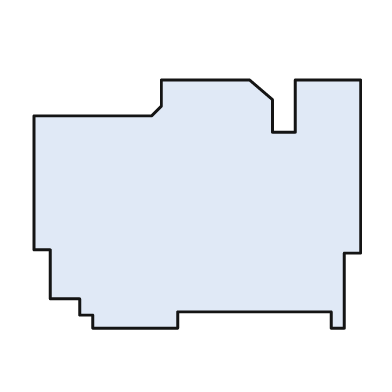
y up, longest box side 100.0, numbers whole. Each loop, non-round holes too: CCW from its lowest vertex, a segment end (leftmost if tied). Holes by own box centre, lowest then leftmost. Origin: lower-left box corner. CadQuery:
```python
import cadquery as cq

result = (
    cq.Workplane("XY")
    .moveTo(18.0, 0.0)
    .lineTo(44.0, 0.0)
    .lineTo(44.0, 5.0)
    .lineTo(91.0, 5.0)
    .lineTo(91.0, 0.0)
    .lineTo(95.0, 0.0)
    .lineTo(95.0, 23.0)
    .lineTo(100.0, 23.0)
    .lineTo(100.0, 76.0)
    .lineTo(80.0, 76.0)
    .lineTo(80.0, 60.0)
    .lineTo(73.0, 60.0)
    .lineTo(73.0, 70.0)
    .lineTo(66.0, 76.0)
    .lineTo(39.0, 76.0)
    .lineTo(39.0, 68.0)
    .lineTo(36.0, 65.0)
    .lineTo(0.0, 65.0)
    .lineTo(0.0, 24.0)
    .lineTo(5.0, 24.0)
    .lineTo(5.0, 9.0)
    .lineTo(14.0, 9.0)
    .lineTo(14.0, 4.0)
    .lineTo(18.0, 4.0)
    .close()
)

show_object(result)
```